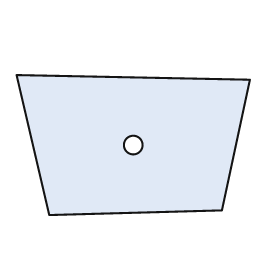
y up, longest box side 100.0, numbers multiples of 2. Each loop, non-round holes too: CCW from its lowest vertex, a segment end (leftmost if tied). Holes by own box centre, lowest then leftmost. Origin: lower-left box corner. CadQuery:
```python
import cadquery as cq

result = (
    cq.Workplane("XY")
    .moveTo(14.0, 0.0)
    .lineTo(88.0, 2.0)
    .lineTo(100.0, 58.0)
    .lineTo(0.0, 60.0)
    .close()
    .moveTo(50.0, 30.0)
    .circle(4.0)
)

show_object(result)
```